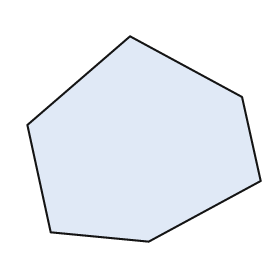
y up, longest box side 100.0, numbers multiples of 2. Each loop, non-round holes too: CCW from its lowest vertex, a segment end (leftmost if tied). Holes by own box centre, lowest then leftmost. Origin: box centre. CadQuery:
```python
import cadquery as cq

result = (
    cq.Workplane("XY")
    .moveTo(2.0, -44.0)
    .lineTo(50.0, -18.0)
    .lineTo(42.0, 18.0)
    .lineTo(-6.0, 44.0)
    .lineTo(-50.0, 6.0)
    .lineTo(-40.0, -40.0)
    .close()
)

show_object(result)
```